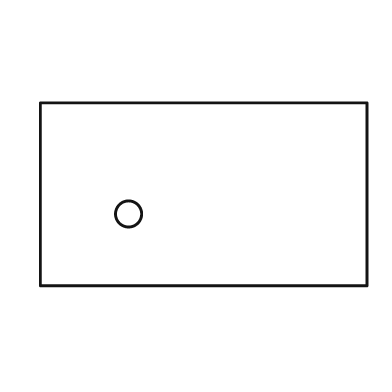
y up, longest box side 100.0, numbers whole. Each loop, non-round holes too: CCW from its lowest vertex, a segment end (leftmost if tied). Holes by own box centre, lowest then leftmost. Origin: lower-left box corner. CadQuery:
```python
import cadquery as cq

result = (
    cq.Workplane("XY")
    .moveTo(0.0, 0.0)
    .lineTo(100.0, 0.0)
    .lineTo(100.0, 56.0)
    .lineTo(0.0, 56.0)
    .close()
    .moveTo(27.0, 22.0)
    .circle(4.0)
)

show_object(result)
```